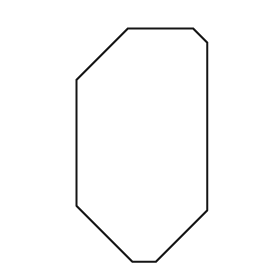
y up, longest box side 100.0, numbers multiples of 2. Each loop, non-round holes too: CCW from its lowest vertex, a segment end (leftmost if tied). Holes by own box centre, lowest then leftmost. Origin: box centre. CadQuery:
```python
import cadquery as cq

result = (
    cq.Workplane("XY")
    .moveTo(-4.0, -50.0)
    .lineTo(6.0, -50.0)
    .lineTo(28.0, -28.0)
    .lineTo(28.0, 44.0)
    .lineTo(22.0, 50.0)
    .lineTo(-6.0, 50.0)
    .lineTo(-28.0, 28.0)
    .lineTo(-28.0, -26.0)
    .close()
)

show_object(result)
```